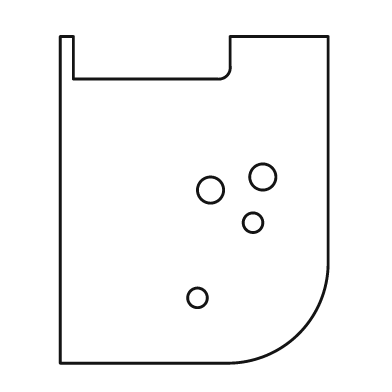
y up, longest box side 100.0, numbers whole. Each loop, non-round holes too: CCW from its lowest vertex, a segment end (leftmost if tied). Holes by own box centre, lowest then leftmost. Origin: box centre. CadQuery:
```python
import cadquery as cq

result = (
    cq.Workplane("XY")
    .moveTo(-41.0, -50.0)
    .lineTo(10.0, -50.0)
    .threePointArc((32.0, -41.0), (41.0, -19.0))
    .lineTo(41.0, 50.0)
    .lineTo(11.0, 50.0)
    .lineTo(11.0, 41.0)
    .threePointArc((10.0, 38.0), (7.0, 37.0))
    .lineTo(-37.0, 37.0)
    .lineTo(-37.0, 50.0)
    .lineTo(-41.0, 50.0)
    .close()
    .moveTo(1.0, -30.0)
    .circle(3.0)
    .moveTo(18.0, -7.0)
    .circle(3.0)
    .moveTo(5.0, 3.0)
    .circle(4.0)
    .moveTo(21.0, 7.0)
    .circle(4.0)
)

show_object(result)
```